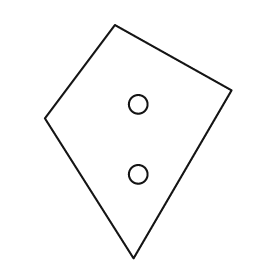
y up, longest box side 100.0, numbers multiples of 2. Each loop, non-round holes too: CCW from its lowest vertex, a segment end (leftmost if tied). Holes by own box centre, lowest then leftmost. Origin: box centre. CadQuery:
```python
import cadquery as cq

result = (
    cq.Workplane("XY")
    .moveTo(-2.0, -50.0)
    .lineTo(40.0, 22.0)
    .lineTo(-10.0, 50.0)
    .lineTo(-40.0, 10.0)
    .close()
    .moveTo(0.0, -14.0)
    .circle(4.0)
    .moveTo(0.0, 16.0)
    .circle(4.0)
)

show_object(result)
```